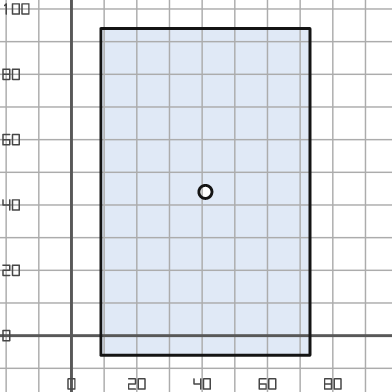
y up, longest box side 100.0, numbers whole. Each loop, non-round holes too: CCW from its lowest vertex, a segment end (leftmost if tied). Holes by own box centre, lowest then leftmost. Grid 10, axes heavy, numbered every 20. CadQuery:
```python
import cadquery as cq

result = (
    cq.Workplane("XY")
    .moveTo(9.0, -6.0)
    .lineTo(73.0, -6.0)
    .lineTo(73.0, 94.0)
    .lineTo(9.0, 94.0)
    .close()
    .moveTo(41.0, 44.0)
    .circle(2.0)
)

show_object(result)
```